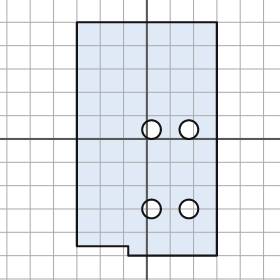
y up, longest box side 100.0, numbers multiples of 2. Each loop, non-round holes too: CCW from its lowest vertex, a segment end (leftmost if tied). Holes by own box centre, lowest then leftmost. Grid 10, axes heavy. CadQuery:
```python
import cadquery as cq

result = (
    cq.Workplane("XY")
    .moveTo(-8.0, -50.0)
    .lineTo(30.0, -50.0)
    .lineTo(30.0, 50.0)
    .lineTo(-30.0, 50.0)
    .lineTo(-30.0, -46.0)
    .lineTo(-8.0, -46.0)
    .close()
    .moveTo(2.0, -30.0)
    .circle(4.0)
    .moveTo(18.0, -30.0)
    .circle(4.0)
    .moveTo(2.0, 4.0)
    .circle(4.0)
    .moveTo(18.0, 4.0)
    .circle(4.0)
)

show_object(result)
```